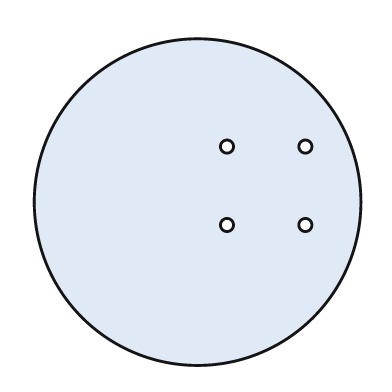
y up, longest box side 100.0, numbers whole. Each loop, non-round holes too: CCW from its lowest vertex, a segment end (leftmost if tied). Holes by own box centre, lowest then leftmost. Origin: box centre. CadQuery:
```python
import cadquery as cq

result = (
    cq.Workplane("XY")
    .moveTo(0.0, 0.0)
    .circle(50.0)
    .moveTo(9.0, -7.0)
    .circle(2.0)
    .moveTo(33.0, -7.0)
    .circle(2.0)
    .moveTo(9.0, 17.0)
    .circle(2.0)
    .moveTo(33.0, 17.0)
    .circle(2.0)
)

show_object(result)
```